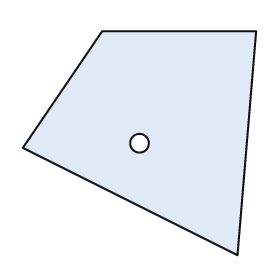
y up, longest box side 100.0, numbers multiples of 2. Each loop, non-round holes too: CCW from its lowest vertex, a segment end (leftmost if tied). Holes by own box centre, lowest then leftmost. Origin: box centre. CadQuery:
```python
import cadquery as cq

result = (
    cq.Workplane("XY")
    .moveTo(42.0, -48.0)
    .lineTo(50.0, 48.0)
    .lineTo(-16.0, 48.0)
    .lineTo(-50.0, -2.0)
    .close()
    .moveTo(0.0, 0.0)
    .circle(4.0)
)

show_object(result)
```